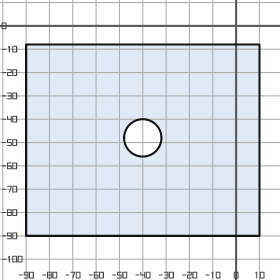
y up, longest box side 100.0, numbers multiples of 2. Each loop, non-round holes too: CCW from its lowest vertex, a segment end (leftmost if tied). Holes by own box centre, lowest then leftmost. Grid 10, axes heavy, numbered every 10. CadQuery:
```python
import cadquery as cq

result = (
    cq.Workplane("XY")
    .moveTo(-90.0, -90.0)
    .lineTo(10.0, -90.0)
    .lineTo(10.0, -8.0)
    .lineTo(-90.0, -8.0)
    .close()
    .moveTo(-40.0, -48.0)
    .circle(8.0)
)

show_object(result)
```